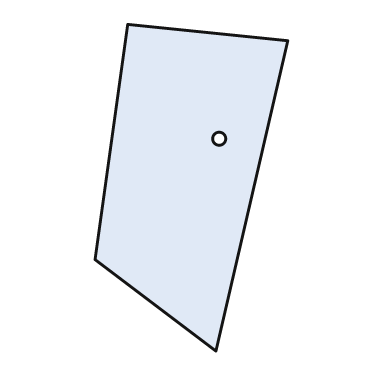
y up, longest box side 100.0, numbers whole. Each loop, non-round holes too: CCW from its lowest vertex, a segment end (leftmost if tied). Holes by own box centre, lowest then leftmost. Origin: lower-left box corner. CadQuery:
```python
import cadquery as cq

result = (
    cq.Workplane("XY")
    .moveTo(37.0, 0.0)
    .lineTo(59.0, 95.0)
    .lineTo(10.0, 100.0)
    .lineTo(0.0, 28.0)
    .close()
    .moveTo(38.0, 65.0)
    .circle(2.0)
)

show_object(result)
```